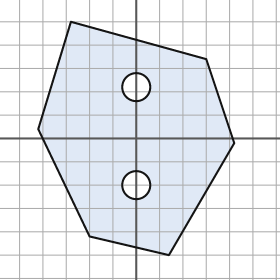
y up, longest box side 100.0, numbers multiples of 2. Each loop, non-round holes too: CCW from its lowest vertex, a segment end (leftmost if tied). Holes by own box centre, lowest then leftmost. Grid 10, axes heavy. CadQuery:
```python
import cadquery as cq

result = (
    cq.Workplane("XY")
    .moveTo(14.0, -50.0)
    .lineTo(42.0, -2.0)
    .lineTo(30.0, 34.0)
    .lineTo(-28.0, 50.0)
    .lineTo(-42.0, 4.0)
    .lineTo(-20.0, -42.0)
    .close()
    .moveTo(0.0, -20.0)
    .circle(6.0)
    .moveTo(0.0, 22.0)
    .circle(6.0)
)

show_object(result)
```